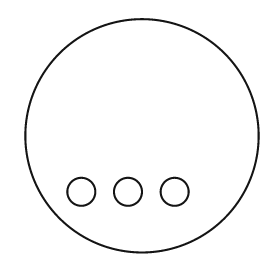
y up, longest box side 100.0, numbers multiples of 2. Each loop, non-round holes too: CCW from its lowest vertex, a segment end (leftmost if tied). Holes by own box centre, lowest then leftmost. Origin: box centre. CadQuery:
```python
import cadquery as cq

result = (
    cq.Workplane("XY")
    .moveTo(0.0, 0.0)
    .circle(50.0)
    .moveTo(-26.0, -24.0)
    .circle(6.0)
    .moveTo(-6.0, -24.0)
    .circle(6.0)
    .moveTo(14.0, -24.0)
    .circle(6.0)
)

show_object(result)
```